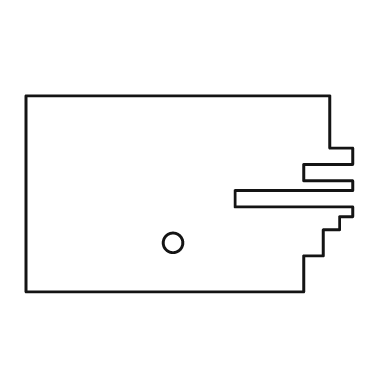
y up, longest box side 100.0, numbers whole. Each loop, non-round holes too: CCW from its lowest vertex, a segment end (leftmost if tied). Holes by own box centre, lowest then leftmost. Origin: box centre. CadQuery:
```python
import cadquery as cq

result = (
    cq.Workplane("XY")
    .moveTo(-50.0, -30.0)
    .lineTo(35.0, -30.0)
    .lineTo(35.0, -19.0)
    .lineTo(41.0, -19.0)
    .lineTo(41.0, -11.0)
    .lineTo(46.0, -11.0)
    .lineTo(46.0, -7.0)
    .lineTo(50.0, -7.0)
    .lineTo(50.0, -4.0)
    .lineTo(14.0, -4.0)
    .lineTo(14.0, 1.0)
    .lineTo(50.0, 1.0)
    .lineTo(50.0, 4.0)
    .lineTo(35.0, 4.0)
    .lineTo(35.0, 9.0)
    .lineTo(50.0, 9.0)
    .lineTo(50.0, 14.0)
    .lineTo(43.0, 14.0)
    .lineTo(43.0, 30.0)
    .lineTo(-50.0, 30.0)
    .close()
    .moveTo(-5.0, -15.0)
    .circle(3.0)
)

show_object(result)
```